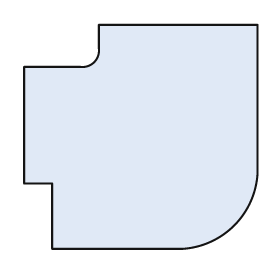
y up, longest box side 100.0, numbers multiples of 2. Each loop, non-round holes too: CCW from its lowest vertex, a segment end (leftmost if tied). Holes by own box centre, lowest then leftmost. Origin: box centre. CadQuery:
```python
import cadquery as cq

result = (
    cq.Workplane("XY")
    .moveTo(-38.0, -48.0)
    .lineTo(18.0, -48.0)
    .threePointArc((40.0, -38.0), (50.0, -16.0))
    .lineTo(50.0, 48.0)
    .lineTo(-18.0, 48.0)
    .lineTo(-18.0, 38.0)
    .threePointArc((-20.0, 32.0), (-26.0, 30.0))
    .lineTo(-50.0, 30.0)
    .lineTo(-50.0, -20.0)
    .lineTo(-38.0, -20.0)
    .close()
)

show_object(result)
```